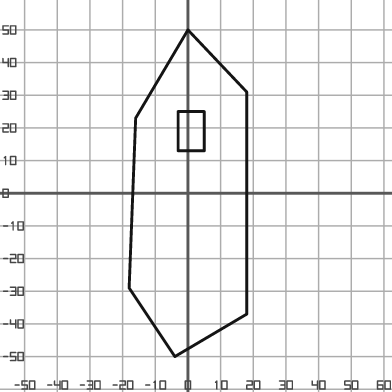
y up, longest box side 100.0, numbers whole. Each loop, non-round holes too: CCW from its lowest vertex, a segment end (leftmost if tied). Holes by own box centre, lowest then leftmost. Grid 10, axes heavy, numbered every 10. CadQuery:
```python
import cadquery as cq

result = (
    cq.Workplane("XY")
    .moveTo(-4.0, -50.0)
    .lineTo(18.0, -37.0)
    .lineTo(18.0, 31.0)
    .lineTo(0.0, 50.0)
    .lineTo(-16.0, 23.0)
    .lineTo(-18.0, -29.0)
    .close()
    .moveTo(-3.0, 13.0)
    .lineTo(5.0, 13.0)
    .lineTo(5.0, 25.0)
    .lineTo(-3.0, 25.0)
    .close()
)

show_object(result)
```